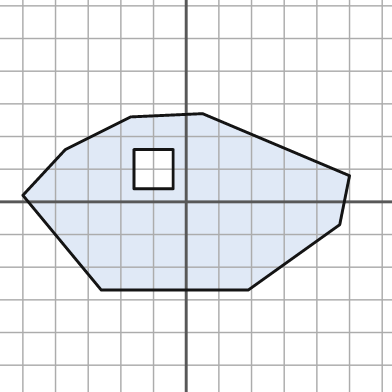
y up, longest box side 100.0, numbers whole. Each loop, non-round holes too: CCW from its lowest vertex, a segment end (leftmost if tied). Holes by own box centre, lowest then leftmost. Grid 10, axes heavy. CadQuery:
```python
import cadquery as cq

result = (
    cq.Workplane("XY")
    .moveTo(-26.0, -27.0)
    .lineTo(19.0, -27.0)
    .lineTo(47.0, -7.0)
    .lineTo(50.0, 8.0)
    .lineTo(5.0, 27.0)
    .lineTo(-17.0, 26.0)
    .lineTo(-37.0, 16.0)
    .lineTo(-50.0, 2.0)
    .close()
    .moveTo(-16.0, 4.0)
    .lineTo(-4.0, 4.0)
    .lineTo(-4.0, 16.0)
    .lineTo(-16.0, 16.0)
    .close()
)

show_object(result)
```